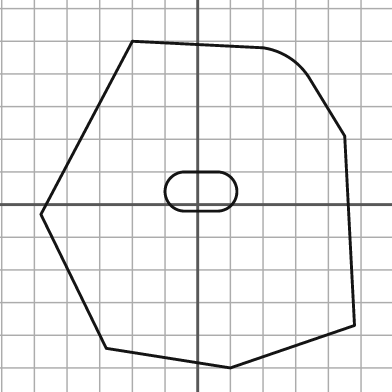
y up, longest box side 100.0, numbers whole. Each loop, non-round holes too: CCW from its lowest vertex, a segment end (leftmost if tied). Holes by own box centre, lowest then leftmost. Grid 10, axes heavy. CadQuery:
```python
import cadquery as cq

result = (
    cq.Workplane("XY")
    .moveTo(10.0, -50.0)
    .lineTo(48.0, -37.0)
    .lineTo(45.0, 21.0)
    .lineTo(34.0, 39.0)
    .threePointArc((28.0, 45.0), (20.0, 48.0))
    .lineTo(-20.0, 50.0)
    .lineTo(-48.0, -3.0)
    .lineTo(-28.0, -44.0)
    .close()
    .moveTo(-4.0, -2.0)
    .lineTo(6.0, -2.0)
    .threePointArc((12.0, 4.0), (6.0, 10.0))
    .lineTo(-4.0, 10.0)
    .threePointArc((-10.0, 4.0), (-4.0, -2.0))
    .close()
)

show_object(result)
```